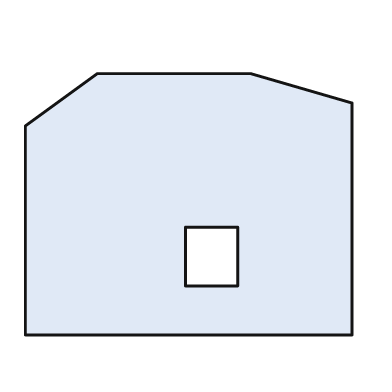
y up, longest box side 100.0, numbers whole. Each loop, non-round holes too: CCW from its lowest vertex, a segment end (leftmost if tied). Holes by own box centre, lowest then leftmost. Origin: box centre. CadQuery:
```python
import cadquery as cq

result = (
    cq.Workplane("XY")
    .moveTo(-50.0, -40.0)
    .lineTo(50.0, -40.0)
    .lineTo(50.0, 31.0)
    .lineTo(19.0, 40.0)
    .lineTo(-28.0, 40.0)
    .lineTo(-50.0, 24.0)
    .close()
    .moveTo(-1.0, -25.0)
    .lineTo(15.0, -25.0)
    .lineTo(15.0, -7.0)
    .lineTo(-1.0, -7.0)
    .close()
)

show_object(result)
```